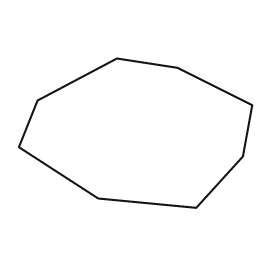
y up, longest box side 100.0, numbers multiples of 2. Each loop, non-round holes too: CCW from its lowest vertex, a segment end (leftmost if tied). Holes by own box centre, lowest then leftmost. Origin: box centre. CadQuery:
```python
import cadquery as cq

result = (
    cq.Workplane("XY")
    .moveTo(26.0, -32.0)
    .lineTo(46.0, -10.0)
    .lineTo(50.0, 12.0)
    .lineTo(18.0, 28.0)
    .lineTo(-8.0, 32.0)
    .lineTo(-42.0, 14.0)
    .lineTo(-50.0, -6.0)
    .lineTo(-16.0, -28.0)
    .close()
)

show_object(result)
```